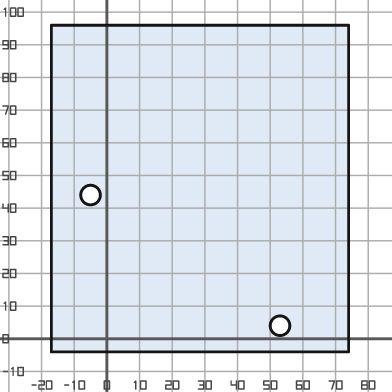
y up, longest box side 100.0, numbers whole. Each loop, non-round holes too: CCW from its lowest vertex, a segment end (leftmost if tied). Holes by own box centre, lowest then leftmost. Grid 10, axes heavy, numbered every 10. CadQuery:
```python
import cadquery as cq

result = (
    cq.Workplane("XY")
    .moveTo(-17.0, -4.0)
    .lineTo(74.0, -4.0)
    .lineTo(74.0, 96.0)
    .lineTo(-17.0, 96.0)
    .close()
    .moveTo(53.0, 4.0)
    .circle(3.0)
    .moveTo(-5.0, 44.0)
    .circle(3.0)
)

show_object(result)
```